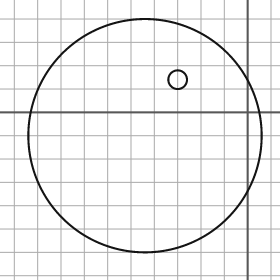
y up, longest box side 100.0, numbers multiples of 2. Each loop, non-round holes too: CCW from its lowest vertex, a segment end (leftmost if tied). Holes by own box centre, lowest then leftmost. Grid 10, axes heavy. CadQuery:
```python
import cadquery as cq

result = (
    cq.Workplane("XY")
    .moveTo(-44.0, -10.0)
    .circle(50.0)
    .moveTo(-30.0, 14.0)
    .circle(4.0)
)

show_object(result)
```